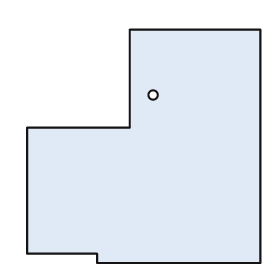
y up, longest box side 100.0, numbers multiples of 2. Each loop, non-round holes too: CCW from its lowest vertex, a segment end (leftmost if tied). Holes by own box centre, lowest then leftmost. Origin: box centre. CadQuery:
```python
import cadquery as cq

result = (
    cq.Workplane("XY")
    .moveTo(-20.0, -50.0)
    .lineTo(50.0, -50.0)
    .lineTo(50.0, 50.0)
    .lineTo(-6.0, 50.0)
    .lineTo(-6.0, 8.0)
    .lineTo(-50.0, 8.0)
    .lineTo(-50.0, -46.0)
    .lineTo(-20.0, -46.0)
    .close()
    .moveTo(4.0, 22.0)
    .circle(2.0)
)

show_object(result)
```